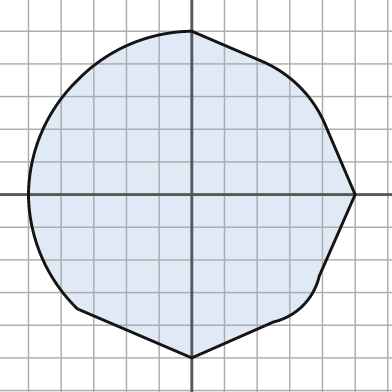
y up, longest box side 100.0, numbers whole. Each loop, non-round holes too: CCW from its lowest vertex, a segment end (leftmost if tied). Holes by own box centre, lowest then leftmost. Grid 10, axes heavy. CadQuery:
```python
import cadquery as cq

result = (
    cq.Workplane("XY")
    .moveTo(0.0, -50.0)
    .lineTo(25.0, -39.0)
    .threePointArc((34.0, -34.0), (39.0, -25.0))
    .lineTo(50.0, 0.0)
    .lineTo(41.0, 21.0)
    .threePointArc((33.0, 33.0), (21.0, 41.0))
    .lineTo(0.0, 50.0)
    .threePointArc((-19.0, 46.0), (-35.0, 35.0))
    .threePointArc((-46.0, 19.0), (-50.0, 0.0))
    .threePointArc((-46.0, -19.0), (-35.0, -35.0))
    .close()
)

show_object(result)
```